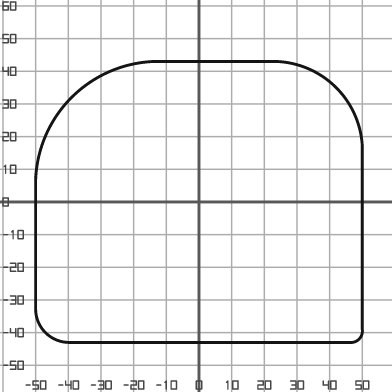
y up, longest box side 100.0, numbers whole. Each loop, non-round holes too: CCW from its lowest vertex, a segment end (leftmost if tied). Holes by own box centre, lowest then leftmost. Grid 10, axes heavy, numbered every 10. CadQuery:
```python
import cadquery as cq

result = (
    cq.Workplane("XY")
    .moveTo(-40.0, -43.0)
    .lineTo(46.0, -43.0)
    .threePointArc((49.0, -42.0), (50.0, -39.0))
    .lineTo(50.0, 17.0)
    .threePointArc((42.0, 35.0), (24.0, 43.0))
    .lineTo(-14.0, 43.0)
    .threePointArc((-39.0, 32.0), (-50.0, 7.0))
    .lineTo(-50.0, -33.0)
    .threePointArc((-47.0, -40.0), (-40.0, -43.0))
    .close()
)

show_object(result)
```